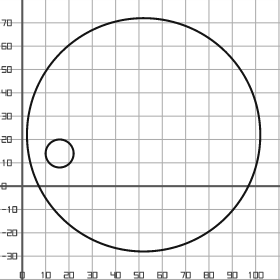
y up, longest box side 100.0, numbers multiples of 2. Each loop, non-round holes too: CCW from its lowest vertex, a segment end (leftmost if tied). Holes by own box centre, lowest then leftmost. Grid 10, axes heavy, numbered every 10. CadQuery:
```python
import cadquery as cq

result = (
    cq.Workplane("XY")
    .moveTo(52.0, 22.0)
    .circle(50.0)
    .moveTo(16.0, 14.0)
    .circle(6.0)
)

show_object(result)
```